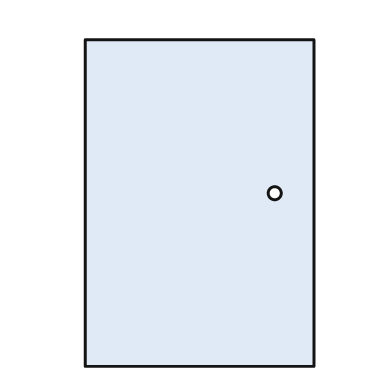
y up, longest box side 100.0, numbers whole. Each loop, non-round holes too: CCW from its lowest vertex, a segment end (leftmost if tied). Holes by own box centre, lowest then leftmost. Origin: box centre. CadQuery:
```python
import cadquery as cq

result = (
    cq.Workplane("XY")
    .moveTo(-35.0, -50.0)
    .lineTo(35.0, -50.0)
    .lineTo(35.0, 50.0)
    .lineTo(-35.0, 50.0)
    .close()
    .moveTo(23.0, 3.0)
    .circle(2.0)
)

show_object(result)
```